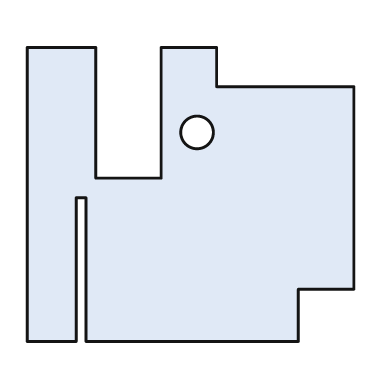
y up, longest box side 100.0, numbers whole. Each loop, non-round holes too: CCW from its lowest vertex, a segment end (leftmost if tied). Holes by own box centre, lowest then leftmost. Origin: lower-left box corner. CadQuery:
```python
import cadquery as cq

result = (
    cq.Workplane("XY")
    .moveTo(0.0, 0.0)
    .lineTo(15.0, 0.0)
    .lineTo(15.0, 44.0)
    .lineTo(18.0, 44.0)
    .lineTo(18.0, 0.0)
    .lineTo(83.0, 0.0)
    .lineTo(83.0, 16.0)
    .lineTo(100.0, 16.0)
    .lineTo(100.0, 78.0)
    .lineTo(58.0, 78.0)
    .lineTo(58.0, 90.0)
    .lineTo(41.0, 90.0)
    .lineTo(41.0, 50.0)
    .lineTo(21.0, 50.0)
    .lineTo(21.0, 90.0)
    .lineTo(0.0, 90.0)
    .close()
    .moveTo(52.0, 64.0)
    .circle(5.0)
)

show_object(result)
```